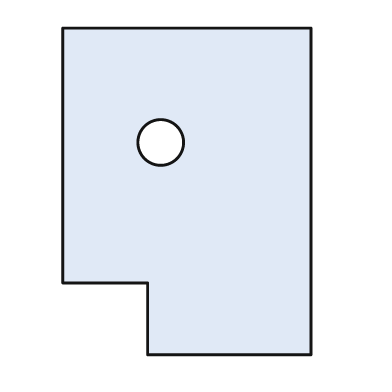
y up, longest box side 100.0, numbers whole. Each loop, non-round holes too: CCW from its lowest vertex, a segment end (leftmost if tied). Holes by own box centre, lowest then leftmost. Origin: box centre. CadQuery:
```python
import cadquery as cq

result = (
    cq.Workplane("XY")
    .moveTo(-12.0, -50.0)
    .lineTo(38.0, -50.0)
    .lineTo(38.0, 50.0)
    .lineTo(-38.0, 50.0)
    .lineTo(-38.0, -28.0)
    .lineTo(-12.0, -28.0)
    .close()
    .moveTo(-8.0, 15.0)
    .circle(7.0)
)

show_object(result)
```